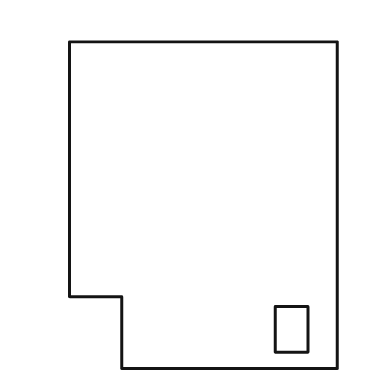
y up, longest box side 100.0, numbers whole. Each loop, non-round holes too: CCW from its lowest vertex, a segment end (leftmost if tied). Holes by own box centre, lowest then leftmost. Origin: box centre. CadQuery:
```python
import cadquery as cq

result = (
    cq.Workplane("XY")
    .moveTo(-25.0, -50.0)
    .lineTo(41.0, -50.0)
    .lineTo(41.0, 50.0)
    .lineTo(-41.0, 50.0)
    .lineTo(-41.0, -28.0)
    .lineTo(-25.0, -28.0)
    .close()
    .moveTo(22.0, -45.0)
    .lineTo(32.0, -45.0)
    .lineTo(32.0, -31.0)
    .lineTo(22.0, -31.0)
    .close()
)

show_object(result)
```